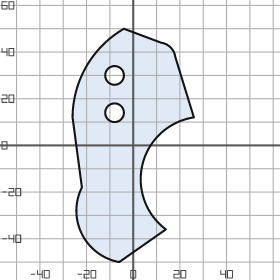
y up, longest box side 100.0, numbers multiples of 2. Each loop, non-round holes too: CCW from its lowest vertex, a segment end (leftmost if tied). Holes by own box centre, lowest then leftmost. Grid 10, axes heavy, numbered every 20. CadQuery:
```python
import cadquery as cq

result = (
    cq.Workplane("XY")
    .moveTo(-6.0, -50.0)
    .lineTo(14.0, -36.0)
    .threePointArc((4.0, -8.0), (26.0, 12.0))
    .lineTo(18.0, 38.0)
    .threePointArc((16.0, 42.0), (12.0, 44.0))
    .lineTo(-4.0, 50.0)
    .threePointArc((-20.0, 34.0), (-26.0, 12.0))
    .lineTo(-22.0, -18.0)
    .threePointArc((-22.0, -38.0), (-6.0, -50.0))
    .close()
    .moveTo(-8.0, 14.0)
    .circle(4.0)
    .moveTo(-8.0, 30.0)
    .circle(4.0)
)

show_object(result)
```